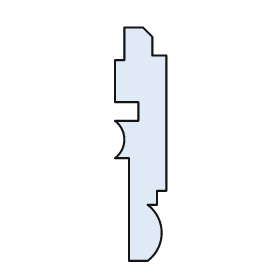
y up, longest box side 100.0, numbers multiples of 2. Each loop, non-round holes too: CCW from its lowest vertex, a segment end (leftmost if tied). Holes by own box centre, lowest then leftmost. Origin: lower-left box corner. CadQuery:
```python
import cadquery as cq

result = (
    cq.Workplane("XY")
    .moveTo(6.0, 0.0)
    .lineTo(14.0, 0.0)
    .threePointArc((20.0, 12.0), (14.0, 24.0))
    .lineTo(18.0, 24.0)
    .lineTo(18.0, 30.0)
    .lineTo(22.0, 30.0)
    .lineTo(22.0, 88.0)
    .lineTo(16.0, 88.0)
    .lineTo(16.0, 96.0)
    .lineTo(12.0, 100.0)
    .lineTo(4.0, 100.0)
    .lineTo(4.0, 86.0)
    .lineTo(0.0, 86.0)
    .lineTo(0.0, 68.0)
    .lineTo(10.0, 68.0)
    .lineTo(10.0, 60.0)
    .lineTo(0.0, 60.0)
    .threePointArc((4.0, 52.0), (0.0, 44.0))
    .lineTo(6.0, 44.0)
    .close()
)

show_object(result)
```